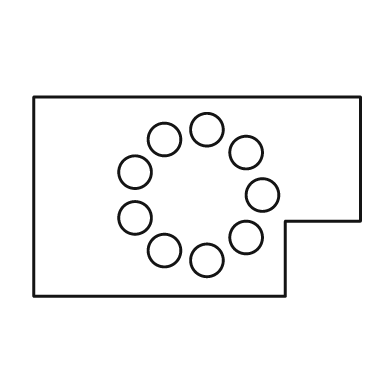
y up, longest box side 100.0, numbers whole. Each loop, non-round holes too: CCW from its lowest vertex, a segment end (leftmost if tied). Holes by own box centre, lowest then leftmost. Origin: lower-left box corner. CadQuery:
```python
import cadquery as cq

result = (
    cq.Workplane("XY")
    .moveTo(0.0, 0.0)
    .lineTo(77.0, 0.0)
    .lineTo(77.0, 23.0)
    .lineTo(100.0, 23.0)
    .lineTo(100.0, 61.0)
    .lineTo(0.0, 61.0)
    .close()
    .moveTo(53.0, 11.0)
    .circle(5.0)
    .moveTo(40.0, 14.0)
    .circle(5.0)
    .moveTo(65.0, 18.0)
    .circle(5.0)
    .moveTo(31.0, 24.0)
    .circle(5.0)
    .moveTo(70.0, 31.0)
    .circle(5.0)
    .moveTo(31.0, 38.0)
    .circle(5.0)
    .moveTo(65.0, 44.0)
    .circle(5.0)
    .moveTo(40.0, 48.0)
    .circle(5.0)
    .moveTo(53.0, 51.0)
    .circle(5.0)
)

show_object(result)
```